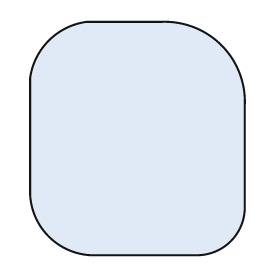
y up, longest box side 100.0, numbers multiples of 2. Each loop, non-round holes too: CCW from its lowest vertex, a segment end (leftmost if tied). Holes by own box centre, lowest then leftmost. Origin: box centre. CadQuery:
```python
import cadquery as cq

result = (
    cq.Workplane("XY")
    .moveTo(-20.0, -50.0)
    .lineTo(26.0, -50.0)
    .threePointArc((40.0, -44.0), (46.0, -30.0))
    .lineTo(46.0, 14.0)
    .threePointArc((36.0, 40.0), (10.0, 50.0))
    .lineTo(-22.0, 50.0)
    .threePointArc((-38.0, 42.0), (-46.0, 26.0))
    .lineTo(-46.0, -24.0)
    .threePointArc((-38.0, -42.0), (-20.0, -50.0))
    .close()
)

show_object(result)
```